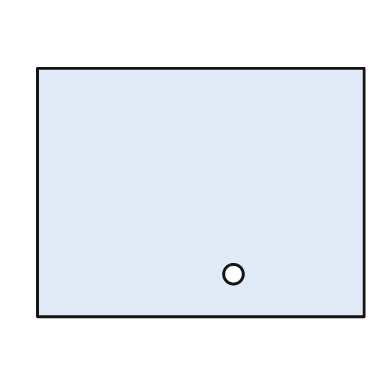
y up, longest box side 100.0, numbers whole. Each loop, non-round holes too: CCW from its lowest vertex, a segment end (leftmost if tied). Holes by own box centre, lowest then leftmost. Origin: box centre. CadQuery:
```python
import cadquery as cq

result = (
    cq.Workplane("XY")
    .moveTo(-50.0, -38.0)
    .lineTo(50.0, -38.0)
    .lineTo(50.0, 38.0)
    .lineTo(-50.0, 38.0)
    .close()
    .moveTo(10.0, -25.0)
    .circle(3.0)
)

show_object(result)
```